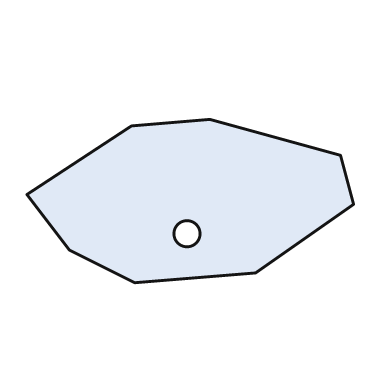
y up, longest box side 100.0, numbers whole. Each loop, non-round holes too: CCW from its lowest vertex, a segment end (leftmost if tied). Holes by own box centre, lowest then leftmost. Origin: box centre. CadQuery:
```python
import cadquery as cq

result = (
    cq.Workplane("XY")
    .moveTo(-17.0, -25.0)
    .lineTo(20.0, -22.0)
    .lineTo(50.0, -1.0)
    .lineTo(46.0, 14.0)
    .lineTo(6.0, 25.0)
    .lineTo(-18.0, 23.0)
    .lineTo(-50.0, 2.0)
    .lineTo(-37.0, -15.0)
    .close()
    .moveTo(-1.0, -10.0)
    .circle(4.0)
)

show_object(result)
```